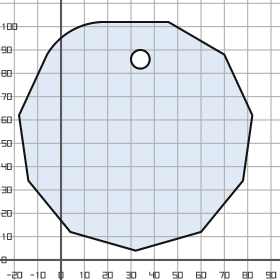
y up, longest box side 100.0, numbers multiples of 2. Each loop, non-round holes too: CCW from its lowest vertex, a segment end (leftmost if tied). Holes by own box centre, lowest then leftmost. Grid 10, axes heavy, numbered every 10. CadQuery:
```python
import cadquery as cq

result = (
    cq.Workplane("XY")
    .moveTo(32.0, 4.0)
    .lineTo(60.0, 12.0)
    .lineTo(78.0, 34.0)
    .lineTo(82.0, 62.0)
    .lineTo(70.0, 88.0)
    .lineTo(46.0, 102.0)
    .lineTo(18.0, 102.0)
    .threePointArc((4.0, 98.0), (-6.0, 88.0))
    .lineTo(-18.0, 62.0)
    .lineTo(-14.0, 34.0)
    .lineTo(4.0, 12.0)
    .close()
    .moveTo(34.0, 86.0)
    .circle(4.0)
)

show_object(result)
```